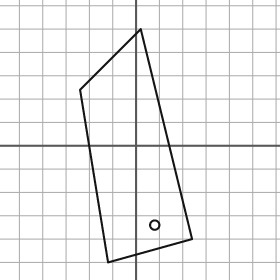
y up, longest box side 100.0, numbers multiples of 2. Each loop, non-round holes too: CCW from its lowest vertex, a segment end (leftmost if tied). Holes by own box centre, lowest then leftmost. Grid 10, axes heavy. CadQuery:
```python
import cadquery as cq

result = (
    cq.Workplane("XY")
    .moveTo(-12.0, -50.0)
    .lineTo(24.0, -40.0)
    .lineTo(2.0, 50.0)
    .lineTo(-24.0, 24.0)
    .close()
    .moveTo(8.0, -34.0)
    .circle(2.0)
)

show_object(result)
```